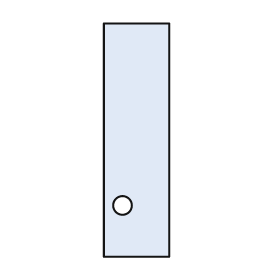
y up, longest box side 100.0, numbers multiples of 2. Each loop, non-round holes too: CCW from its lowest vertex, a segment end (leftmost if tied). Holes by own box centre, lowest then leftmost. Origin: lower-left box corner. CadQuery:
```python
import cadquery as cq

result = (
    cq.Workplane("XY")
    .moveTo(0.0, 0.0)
    .lineTo(28.0, 0.0)
    .lineTo(28.0, 100.0)
    .lineTo(0.0, 100.0)
    .close()
    .moveTo(8.0, 22.0)
    .circle(4.0)
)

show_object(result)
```